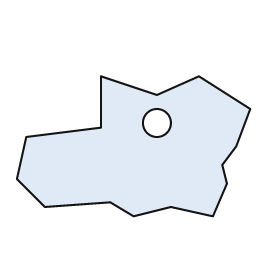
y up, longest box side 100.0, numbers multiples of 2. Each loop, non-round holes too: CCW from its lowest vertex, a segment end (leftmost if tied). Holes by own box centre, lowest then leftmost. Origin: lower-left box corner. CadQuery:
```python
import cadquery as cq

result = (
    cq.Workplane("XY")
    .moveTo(50.0, 0.0)
    .lineTo(66.0, 4.0)
    .lineTo(84.0, 0.0)
    .lineTo(90.0, 14.0)
    .lineTo(88.0, 22.0)
    .lineTo(94.0, 30.0)
    .lineTo(100.0, 46.0)
    .lineTo(78.0, 60.0)
    .lineTo(60.0, 52.0)
    .lineTo(36.0, 60.0)
    .lineTo(36.0, 38.0)
    .lineTo(4.0, 34.0)
    .lineTo(0.0, 16.0)
    .lineTo(12.0, 4.0)
    .lineTo(40.0, 6.0)
    .close()
    .moveTo(60.0, 40.0)
    .circle(6.0)
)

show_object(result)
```